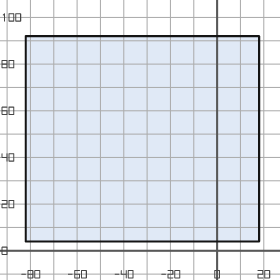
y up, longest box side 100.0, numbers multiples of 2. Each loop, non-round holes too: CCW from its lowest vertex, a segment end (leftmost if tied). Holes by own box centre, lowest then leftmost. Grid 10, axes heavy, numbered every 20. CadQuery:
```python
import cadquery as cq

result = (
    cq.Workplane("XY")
    .moveTo(-82.0, 4.0)
    .lineTo(18.0, 4.0)
    .lineTo(18.0, 92.0)
    .lineTo(-82.0, 92.0)
    .close()
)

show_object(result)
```